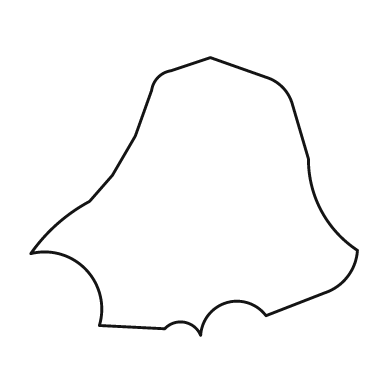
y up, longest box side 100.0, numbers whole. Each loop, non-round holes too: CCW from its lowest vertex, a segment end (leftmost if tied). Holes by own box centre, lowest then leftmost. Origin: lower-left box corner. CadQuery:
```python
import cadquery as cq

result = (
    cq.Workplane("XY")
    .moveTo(52.0, 0.0)
    .threePointArc((60.0, 10.0), (72.0, 6.0))
    .lineTo(90.0, 13.0)
    .threePointArc((97.0, 18.0), (100.0, 26.0))
    .threePointArc((89.0, 38.0), (85.0, 54.0))
    .lineTo(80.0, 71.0)
    .threePointArc((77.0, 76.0), (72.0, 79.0))
    .lineTo(55.0, 85.0)
    .lineTo(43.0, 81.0)
    .threePointArc((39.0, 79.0), (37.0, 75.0))
    .lineTo(32.0, 61.0)
    .lineTo(25.0, 49.0)
    .lineTo(18.0, 41.0)
    .threePointArc((8.0, 34.0), (0.0, 25.0))
    .threePointArc((17.0, 20.0), (21.0, 3.0))
    .lineTo(41.0, 2.0)
    .threePointArc((47.0, 4.0), (52.0, 0.0))
    .close()
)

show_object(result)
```